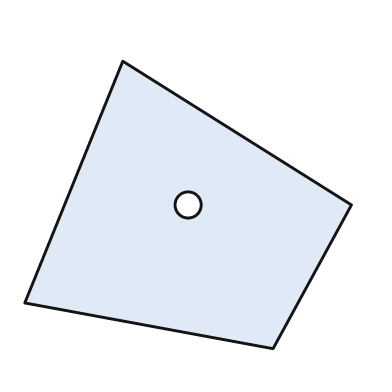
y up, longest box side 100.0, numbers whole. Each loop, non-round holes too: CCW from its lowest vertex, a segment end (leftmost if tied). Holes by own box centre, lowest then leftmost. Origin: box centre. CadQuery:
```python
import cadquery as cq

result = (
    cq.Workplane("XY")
    .moveTo(26.0, -44.0)
    .lineTo(50.0, 0.0)
    .lineTo(-20.0, 44.0)
    .lineTo(-50.0, -30.0)
    .close()
    .moveTo(0.0, 0.0)
    .circle(4.0)
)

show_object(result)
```